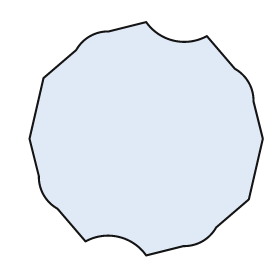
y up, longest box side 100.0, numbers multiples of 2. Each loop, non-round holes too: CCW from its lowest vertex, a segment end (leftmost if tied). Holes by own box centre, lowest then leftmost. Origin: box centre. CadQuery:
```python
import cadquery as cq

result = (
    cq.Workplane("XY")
    .moveTo(0.0, -50.0)
    .lineTo(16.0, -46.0)
    .threePointArc((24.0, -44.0), (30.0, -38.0))
    .lineTo(44.0, -26.0)
    .lineTo(50.0, 0.0)
    .lineTo(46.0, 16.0)
    .threePointArc((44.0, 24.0), (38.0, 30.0))
    .lineTo(26.0, 44.0)
    .threePointArc((12.0, 42.0), (0.0, 50.0))
    .lineTo(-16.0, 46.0)
    .threePointArc((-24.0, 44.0), (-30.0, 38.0))
    .lineTo(-44.0, 26.0)
    .lineTo(-50.0, 0.0)
    .lineTo(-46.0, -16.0)
    .threePointArc((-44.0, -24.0), (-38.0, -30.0))
    .lineTo(-26.0, -44.0)
    .threePointArc((-12.0, -42.0), (0.0, -50.0))
    .close()
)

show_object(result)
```